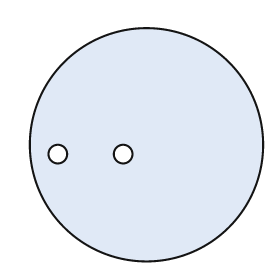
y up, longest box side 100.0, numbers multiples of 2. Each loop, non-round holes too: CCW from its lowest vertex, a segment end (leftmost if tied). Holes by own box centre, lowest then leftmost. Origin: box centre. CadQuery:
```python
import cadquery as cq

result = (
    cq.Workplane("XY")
    .moveTo(0.0, 0.0)
    .circle(50.0)
    .moveTo(-38.0, -4.0)
    .circle(4.0)
    .moveTo(-10.0, -4.0)
    .circle(4.0)
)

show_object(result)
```